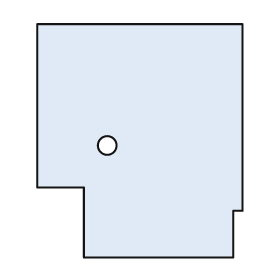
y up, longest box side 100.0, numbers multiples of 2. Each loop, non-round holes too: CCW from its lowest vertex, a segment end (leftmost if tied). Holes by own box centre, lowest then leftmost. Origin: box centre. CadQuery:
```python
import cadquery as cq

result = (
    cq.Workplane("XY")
    .moveTo(-24.0, -50.0)
    .lineTo(40.0, -50.0)
    .lineTo(40.0, -30.0)
    .lineTo(44.0, -30.0)
    .lineTo(44.0, 50.0)
    .lineTo(-44.0, 50.0)
    .lineTo(-44.0, -20.0)
    .lineTo(-24.0, -20.0)
    .close()
    .moveTo(-14.0, -2.0)
    .circle(4.0)
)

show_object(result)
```